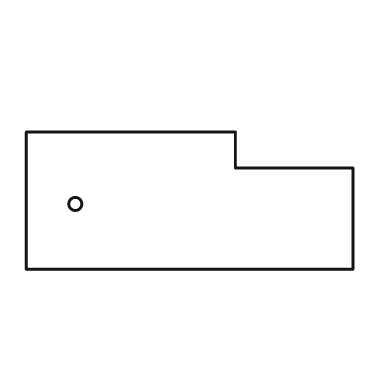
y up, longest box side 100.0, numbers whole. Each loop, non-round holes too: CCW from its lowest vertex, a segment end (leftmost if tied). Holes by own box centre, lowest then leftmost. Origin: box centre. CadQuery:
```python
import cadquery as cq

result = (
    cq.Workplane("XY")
    .moveTo(-50.0, -21.0)
    .lineTo(50.0, -21.0)
    .lineTo(50.0, 10.0)
    .lineTo(14.0, 10.0)
    .lineTo(14.0, 21.0)
    .lineTo(-50.0, 21.0)
    .close()
    .moveTo(-35.0, -1.0)
    .circle(2.0)
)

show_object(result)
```